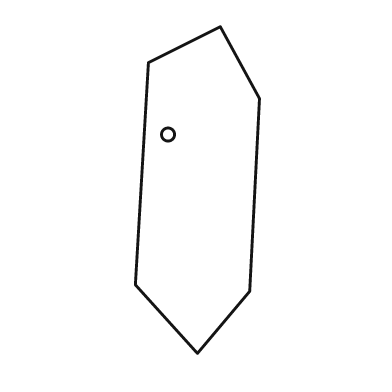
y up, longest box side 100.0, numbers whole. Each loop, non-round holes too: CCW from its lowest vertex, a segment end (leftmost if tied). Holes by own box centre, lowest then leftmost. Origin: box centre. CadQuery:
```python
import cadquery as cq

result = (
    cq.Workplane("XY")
    .moveTo(0.0, -50.0)
    .lineTo(16.0, -31.0)
    .lineTo(19.0, 28.0)
    .lineTo(7.0, 50.0)
    .lineTo(-15.0, 39.0)
    .lineTo(-19.0, -29.0)
    .close()
    .moveTo(-9.0, 17.0)
    .circle(2.0)
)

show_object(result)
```